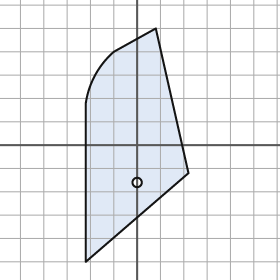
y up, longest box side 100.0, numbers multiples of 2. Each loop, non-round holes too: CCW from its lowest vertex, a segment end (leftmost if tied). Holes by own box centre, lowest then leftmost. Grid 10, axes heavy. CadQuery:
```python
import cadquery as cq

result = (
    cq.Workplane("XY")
    .moveTo(-22.0, -50.0)
    .lineTo(22.0, -12.0)
    .lineTo(8.0, 50.0)
    .lineTo(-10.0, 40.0)
    .threePointArc((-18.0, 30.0), (-22.0, 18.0))
    .close()
    .moveTo(0.0, -16.0)
    .circle(2.0)
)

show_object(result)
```